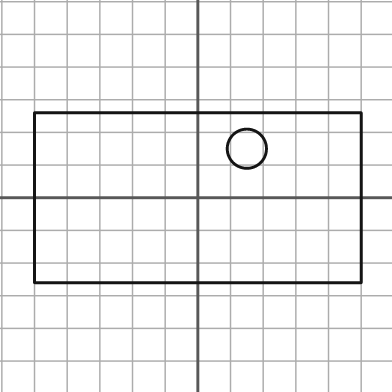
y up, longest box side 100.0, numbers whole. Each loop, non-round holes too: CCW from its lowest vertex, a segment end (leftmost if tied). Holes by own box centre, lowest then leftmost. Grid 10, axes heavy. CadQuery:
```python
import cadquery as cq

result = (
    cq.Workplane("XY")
    .moveTo(-50.0, -26.0)
    .lineTo(50.0, -26.0)
    .lineTo(50.0, 26.0)
    .lineTo(-50.0, 26.0)
    .close()
    .moveTo(15.0, 15.0)
    .circle(6.0)
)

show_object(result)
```